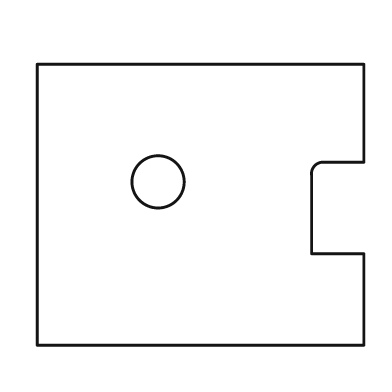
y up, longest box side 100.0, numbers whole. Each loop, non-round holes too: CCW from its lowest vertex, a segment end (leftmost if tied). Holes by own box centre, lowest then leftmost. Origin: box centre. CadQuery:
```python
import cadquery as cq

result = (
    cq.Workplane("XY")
    .moveTo(-50.0, -43.0)
    .lineTo(50.0, -43.0)
    .lineTo(50.0, -15.0)
    .lineTo(34.0, -15.0)
    .lineTo(34.0, 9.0)
    .threePointArc((35.0, 12.0), (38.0, 13.0))
    .lineTo(50.0, 13.0)
    .lineTo(50.0, 43.0)
    .lineTo(-50.0, 43.0)
    .close()
    .moveTo(-13.0, 7.0)
    .circle(8.0)
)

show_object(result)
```